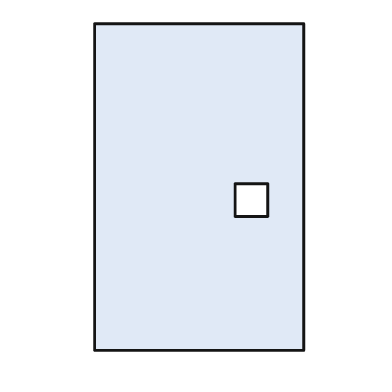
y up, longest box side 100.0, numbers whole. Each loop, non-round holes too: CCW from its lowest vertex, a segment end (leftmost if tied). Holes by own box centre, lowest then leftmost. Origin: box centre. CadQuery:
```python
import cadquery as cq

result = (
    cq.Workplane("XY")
    .moveTo(-32.0, -50.0)
    .lineTo(32.0, -50.0)
    .lineTo(32.0, 50.0)
    .lineTo(-32.0, 50.0)
    .close()
    .moveTo(11.0, -9.0)
    .lineTo(21.0, -9.0)
    .lineTo(21.0, 1.0)
    .lineTo(11.0, 1.0)
    .close()
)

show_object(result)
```